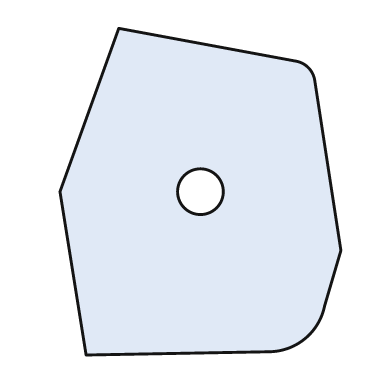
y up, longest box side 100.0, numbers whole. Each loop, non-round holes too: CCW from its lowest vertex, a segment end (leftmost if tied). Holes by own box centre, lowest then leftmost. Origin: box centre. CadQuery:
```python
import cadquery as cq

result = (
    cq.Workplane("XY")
    .moveTo(-35.0, -50.0)
    .lineTo(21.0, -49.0)
    .threePointArc((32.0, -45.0), (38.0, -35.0))
    .lineTo(43.0, -18.0)
    .lineTo(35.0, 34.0)
    .threePointArc((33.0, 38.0), (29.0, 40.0))
    .lineTo(-25.0, 50.0)
    .lineTo(-43.0, 0.0)
    .close()
    .moveTo(0.0, 0.0)
    .circle(7.0)
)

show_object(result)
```